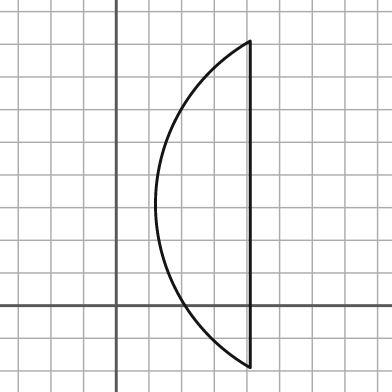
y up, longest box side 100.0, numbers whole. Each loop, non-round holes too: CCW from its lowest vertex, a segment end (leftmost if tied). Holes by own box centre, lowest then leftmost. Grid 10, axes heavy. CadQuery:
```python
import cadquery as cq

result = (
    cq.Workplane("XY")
    .moveTo(41.0, -19.0)
    .lineTo(41.0, 81.0)
    .threePointArc((12.0, 31.0), (41.0, -19.0))
    .close()
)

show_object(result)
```